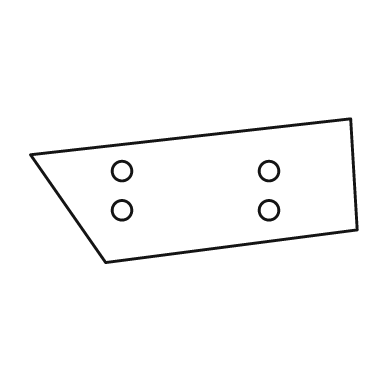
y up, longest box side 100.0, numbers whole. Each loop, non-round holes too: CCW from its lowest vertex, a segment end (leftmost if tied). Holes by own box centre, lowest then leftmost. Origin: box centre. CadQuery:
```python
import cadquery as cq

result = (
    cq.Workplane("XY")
    .moveTo(-27.0, -22.0)
    .lineTo(50.0, -12.0)
    .lineTo(48.0, 22.0)
    .lineTo(-50.0, 11.0)
    .close()
    .moveTo(-22.0, -6.0)
    .circle(3.0)
    .moveTo(23.0, -6.0)
    .circle(3.0)
    .moveTo(-22.0, 6.0)
    .circle(3.0)
    .moveTo(23.0, 6.0)
    .circle(3.0)
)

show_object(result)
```